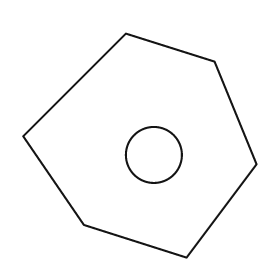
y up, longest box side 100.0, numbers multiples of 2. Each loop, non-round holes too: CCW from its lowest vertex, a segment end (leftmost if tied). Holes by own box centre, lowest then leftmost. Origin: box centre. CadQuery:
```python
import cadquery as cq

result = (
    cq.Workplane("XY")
    .moveTo(20.0, -48.0)
    .lineTo(50.0, -8.0)
    .lineTo(32.0, 36.0)
    .lineTo(-6.0, 48.0)
    .lineTo(-50.0, 4.0)
    .lineTo(-24.0, -34.0)
    .close()
    .moveTo(6.0, -4.0)
    .circle(12.0)
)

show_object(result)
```